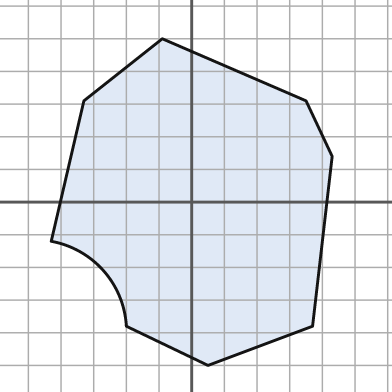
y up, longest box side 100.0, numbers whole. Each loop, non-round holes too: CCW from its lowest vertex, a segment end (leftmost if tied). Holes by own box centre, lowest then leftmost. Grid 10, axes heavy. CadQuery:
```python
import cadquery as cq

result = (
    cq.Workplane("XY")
    .moveTo(5.0, -50.0)
    .lineTo(37.0, -38.0)
    .lineTo(43.0, 14.0)
    .lineTo(35.0, 31.0)
    .lineTo(-9.0, 50.0)
    .lineTo(-33.0, 31.0)
    .lineTo(-43.0, -12.0)
    .threePointArc((-27.0, -21.0), (-20.0, -38.0))
    .close()
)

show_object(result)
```